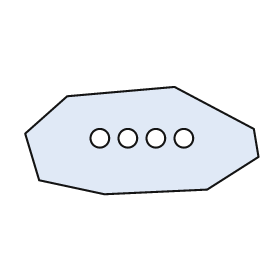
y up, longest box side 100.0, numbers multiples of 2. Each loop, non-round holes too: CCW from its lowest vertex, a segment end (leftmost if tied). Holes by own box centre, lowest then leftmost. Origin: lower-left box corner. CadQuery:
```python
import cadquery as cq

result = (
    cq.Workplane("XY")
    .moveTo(34.0, 0.0)
    .lineTo(78.0, 2.0)
    .lineTo(100.0, 16.0)
    .lineTo(98.0, 28.0)
    .lineTo(64.0, 46.0)
    .lineTo(18.0, 42.0)
    .lineTo(0.0, 26.0)
    .lineTo(6.0, 6.0)
    .close()
    .moveTo(32.0, 24.0)
    .circle(4.0)
    .moveTo(44.0, 24.0)
    .circle(4.0)
    .moveTo(56.0, 24.0)
    .circle(4.0)
    .moveTo(68.0, 24.0)
    .circle(4.0)
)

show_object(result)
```